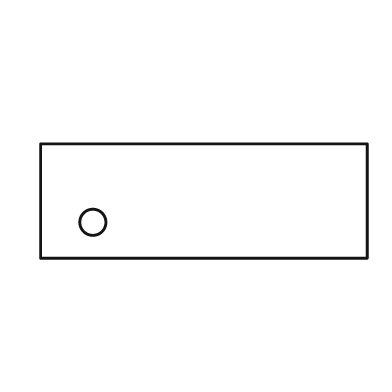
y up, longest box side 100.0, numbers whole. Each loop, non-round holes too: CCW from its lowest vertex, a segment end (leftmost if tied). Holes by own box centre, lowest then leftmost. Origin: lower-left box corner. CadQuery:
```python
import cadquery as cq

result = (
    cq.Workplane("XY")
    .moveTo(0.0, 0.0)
    .lineTo(100.0, 0.0)
    .lineTo(100.0, 35.0)
    .lineTo(0.0, 35.0)
    .close()
    .moveTo(16.0, 11.0)
    .circle(4.0)
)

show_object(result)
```